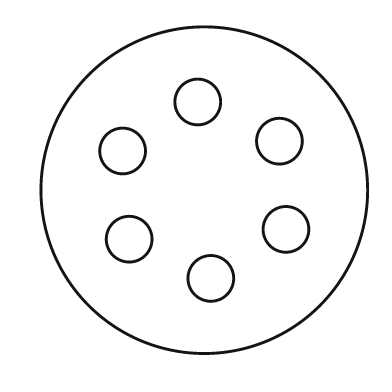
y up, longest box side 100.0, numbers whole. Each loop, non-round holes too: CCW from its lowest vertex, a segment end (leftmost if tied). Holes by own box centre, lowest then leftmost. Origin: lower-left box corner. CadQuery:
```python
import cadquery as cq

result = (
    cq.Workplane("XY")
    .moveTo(50.0, 50.0)
    .circle(50.0)
    .moveTo(52.0, 23.0)
    .circle(7.0)
    .moveTo(27.0, 35.0)
    .circle(7.0)
    .moveTo(75.0, 38.0)
    .circle(7.0)
    .moveTo(25.0, 62.0)
    .circle(7.0)
    .moveTo(73.0, 65.0)
    .circle(7.0)
    .moveTo(48.0, 77.0)
    .circle(7.0)
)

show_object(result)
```